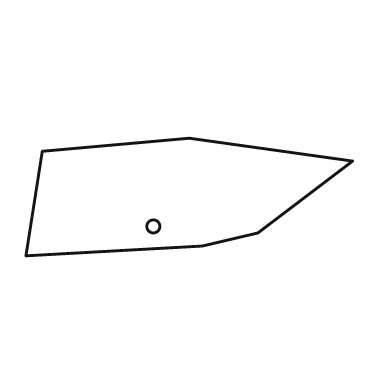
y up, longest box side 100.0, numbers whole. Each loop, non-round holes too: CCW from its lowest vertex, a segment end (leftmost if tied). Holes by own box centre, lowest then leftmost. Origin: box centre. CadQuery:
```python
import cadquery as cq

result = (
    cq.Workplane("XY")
    .moveTo(-50.0, -18.0)
    .lineTo(4.0, -15.0)
    .lineTo(21.0, -11.0)
    .lineTo(50.0, 11.0)
    .lineTo(0.0, 18.0)
    .lineTo(-45.0, 14.0)
    .close()
    .moveTo(-11.0, -9.0)
    .circle(2.0)
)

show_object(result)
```